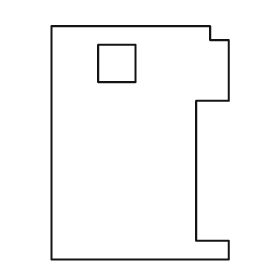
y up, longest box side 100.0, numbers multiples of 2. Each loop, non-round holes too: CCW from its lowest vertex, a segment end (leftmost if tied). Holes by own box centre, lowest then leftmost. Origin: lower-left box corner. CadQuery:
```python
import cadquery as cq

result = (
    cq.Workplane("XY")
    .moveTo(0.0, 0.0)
    .lineTo(76.0, 0.0)
    .lineTo(76.0, 8.0)
    .lineTo(62.0, 8.0)
    .lineTo(62.0, 68.0)
    .lineTo(76.0, 68.0)
    .lineTo(76.0, 94.0)
    .lineTo(68.0, 94.0)
    .lineTo(68.0, 100.0)
    .lineTo(0.0, 100.0)
    .close()
    .moveTo(20.0, 76.0)
    .lineTo(36.0, 76.0)
    .lineTo(36.0, 92.0)
    .lineTo(20.0, 92.0)
    .close()
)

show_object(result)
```